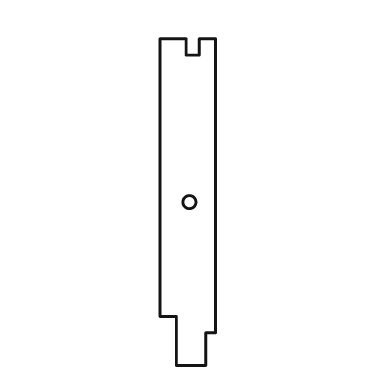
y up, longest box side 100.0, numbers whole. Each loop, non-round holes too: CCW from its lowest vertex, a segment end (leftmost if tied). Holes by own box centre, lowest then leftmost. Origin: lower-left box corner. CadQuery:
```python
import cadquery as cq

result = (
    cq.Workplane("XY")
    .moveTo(5.0, 0.0)
    .lineTo(14.0, 0.0)
    .lineTo(14.0, 10.0)
    .lineTo(17.0, 10.0)
    .lineTo(17.0, 100.0)
    .lineTo(12.0, 100.0)
    .lineTo(12.0, 95.0)
    .lineTo(8.0, 95.0)
    .lineTo(8.0, 100.0)
    .lineTo(0.0, 100.0)
    .lineTo(0.0, 15.0)
    .lineTo(5.0, 15.0)
    .close()
    .moveTo(9.0, 50.0)
    .circle(2.0)
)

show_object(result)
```